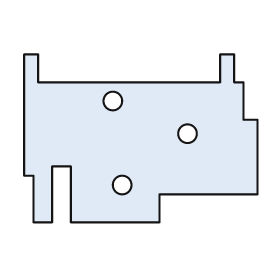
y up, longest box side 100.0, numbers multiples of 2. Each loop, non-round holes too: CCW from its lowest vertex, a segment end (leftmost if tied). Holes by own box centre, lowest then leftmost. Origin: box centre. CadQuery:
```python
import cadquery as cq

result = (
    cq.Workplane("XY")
    .moveTo(-46.0, -36.0)
    .lineTo(-38.0, -36.0)
    .lineTo(-38.0, -12.0)
    .lineTo(-30.0, -12.0)
    .lineTo(-30.0, -36.0)
    .lineTo(8.0, -36.0)
    .lineTo(8.0, -24.0)
    .lineTo(50.0, -24.0)
    .lineTo(50.0, 8.0)
    .lineTo(44.0, 8.0)
    .lineTo(44.0, 24.0)
    .lineTo(40.0, 24.0)
    .lineTo(40.0, 36.0)
    .lineTo(34.0, 36.0)
    .lineTo(34.0, 24.0)
    .lineTo(-44.0, 24.0)
    .lineTo(-44.0, 36.0)
    .lineTo(-50.0, 36.0)
    .lineTo(-50.0, -16.0)
    .lineTo(-46.0, -16.0)
    .close()
    .moveTo(-8.0, -20.0)
    .circle(4.0)
    .moveTo(20.0, 2.0)
    .circle(4.0)
    .moveTo(-12.0, 16.0)
    .circle(4.0)
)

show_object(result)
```